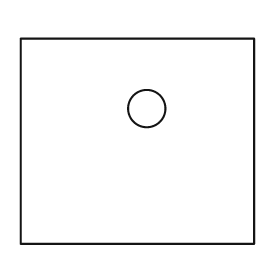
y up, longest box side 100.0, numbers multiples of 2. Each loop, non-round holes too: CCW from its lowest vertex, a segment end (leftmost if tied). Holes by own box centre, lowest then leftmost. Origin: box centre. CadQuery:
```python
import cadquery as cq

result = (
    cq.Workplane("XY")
    .moveTo(-50.0, -44.0)
    .lineTo(50.0, -44.0)
    .lineTo(50.0, 44.0)
    .lineTo(-50.0, 44.0)
    .close()
    .moveTo(4.0, 14.0)
    .circle(8.0)
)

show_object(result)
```